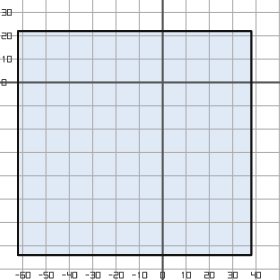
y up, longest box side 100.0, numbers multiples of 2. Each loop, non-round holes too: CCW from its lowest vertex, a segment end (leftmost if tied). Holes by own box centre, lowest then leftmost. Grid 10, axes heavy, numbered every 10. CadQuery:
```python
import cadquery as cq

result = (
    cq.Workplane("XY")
    .moveTo(-62.0, -74.0)
    .lineTo(38.0, -74.0)
    .lineTo(38.0, 22.0)
    .lineTo(-62.0, 22.0)
    .close()
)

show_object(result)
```